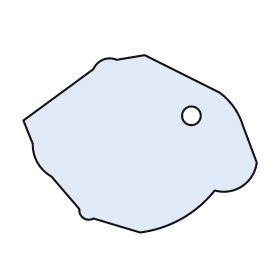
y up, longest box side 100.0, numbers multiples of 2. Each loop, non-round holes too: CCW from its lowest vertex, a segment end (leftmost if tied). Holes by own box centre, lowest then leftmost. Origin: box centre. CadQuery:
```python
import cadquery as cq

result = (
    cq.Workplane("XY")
    .moveTo(0.0, -38.0)
    .threePointArc((18.0, -32.0), (32.0, -20.0))
    .threePointArc((44.0, -18.0), (50.0, -8.0))
    .lineTo(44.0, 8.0)
    .threePointArc((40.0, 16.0), (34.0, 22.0))
    .lineTo(2.0, 38.0)
    .lineTo(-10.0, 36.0)
    .threePointArc((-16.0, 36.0), (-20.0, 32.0))
    .lineTo(-50.0, 10.0)
    .lineTo(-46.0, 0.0)
    .threePointArc((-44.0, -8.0), (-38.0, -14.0))
    .lineTo(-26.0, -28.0)
    .threePointArc((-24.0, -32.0), (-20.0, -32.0))
    .close()
    .moveTo(22.0, 12.0)
    .circle(4.0)
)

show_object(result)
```